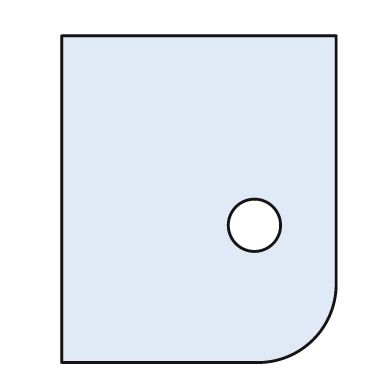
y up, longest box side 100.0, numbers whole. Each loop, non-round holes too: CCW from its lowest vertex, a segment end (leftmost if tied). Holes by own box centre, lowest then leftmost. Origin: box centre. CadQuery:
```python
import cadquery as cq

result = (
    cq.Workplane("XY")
    .moveTo(-42.0, -50.0)
    .lineTo(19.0, -50.0)
    .threePointArc((35.0, -43.0), (42.0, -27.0))
    .lineTo(42.0, 50.0)
    .lineTo(-42.0, 50.0)
    .close()
    .moveTo(17.0, -8.0)
    .circle(8.0)
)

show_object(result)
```